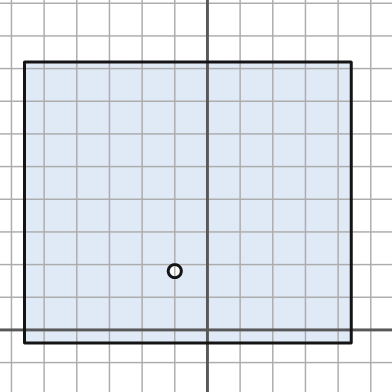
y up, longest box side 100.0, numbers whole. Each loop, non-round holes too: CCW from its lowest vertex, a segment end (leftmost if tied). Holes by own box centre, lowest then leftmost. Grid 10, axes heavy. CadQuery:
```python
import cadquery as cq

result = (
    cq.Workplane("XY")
    .moveTo(-56.0, -4.0)
    .lineTo(44.0, -4.0)
    .lineTo(44.0, 82.0)
    .lineTo(-56.0, 82.0)
    .close()
    .moveTo(-10.0, 18.0)
    .circle(2.0)
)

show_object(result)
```